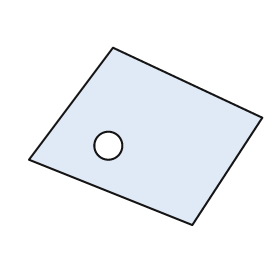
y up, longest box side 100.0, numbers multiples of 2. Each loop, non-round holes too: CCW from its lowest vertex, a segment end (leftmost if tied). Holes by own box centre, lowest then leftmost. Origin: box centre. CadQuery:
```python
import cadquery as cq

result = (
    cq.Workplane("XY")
    .moveTo(20.0, -38.0)
    .lineTo(50.0, 8.0)
    .lineTo(-14.0, 38.0)
    .lineTo(-50.0, -10.0)
    .close()
    .moveTo(-16.0, -4.0)
    .circle(6.0)
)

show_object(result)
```